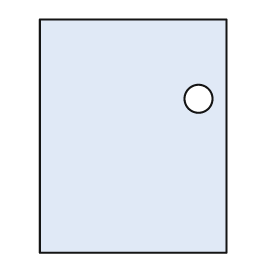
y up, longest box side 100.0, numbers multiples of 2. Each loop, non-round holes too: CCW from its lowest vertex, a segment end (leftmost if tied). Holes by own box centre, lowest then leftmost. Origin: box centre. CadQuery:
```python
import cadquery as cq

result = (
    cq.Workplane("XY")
    .moveTo(-40.0, -50.0)
    .lineTo(40.0, -50.0)
    .lineTo(40.0, 50.0)
    .lineTo(-40.0, 50.0)
    .close()
    .moveTo(28.0, 16.0)
    .circle(6.0)
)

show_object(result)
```